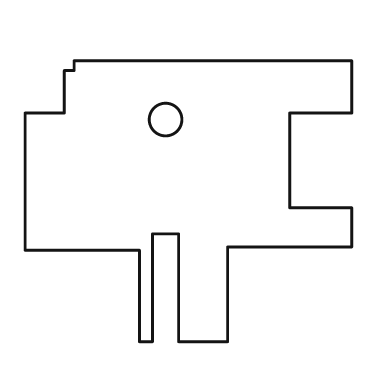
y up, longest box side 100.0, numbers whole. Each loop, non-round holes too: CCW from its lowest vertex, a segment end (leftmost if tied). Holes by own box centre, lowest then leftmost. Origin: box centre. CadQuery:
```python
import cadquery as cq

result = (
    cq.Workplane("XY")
    .moveTo(-15.0, -43.0)
    .lineTo(-11.0, -43.0)
    .lineTo(-11.0, -10.0)
    .lineTo(-3.0, -10.0)
    .lineTo(-3.0, -43.0)
    .lineTo(12.0, -43.0)
    .lineTo(12.0, -14.0)
    .lineTo(50.0, -14.0)
    .lineTo(50.0, -2.0)
    .lineTo(31.0, -2.0)
    .lineTo(31.0, 27.0)
    .lineTo(50.0, 27.0)
    .lineTo(50.0, 43.0)
    .lineTo(-35.0, 43.0)
    .lineTo(-35.0, 40.0)
    .lineTo(-38.0, 40.0)
    .lineTo(-38.0, 27.0)
    .lineTo(-50.0, 27.0)
    .lineTo(-50.0, -15.0)
    .lineTo(-15.0, -15.0)
    .close()
    .moveTo(-7.0, 25.0)
    .circle(5.0)
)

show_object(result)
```